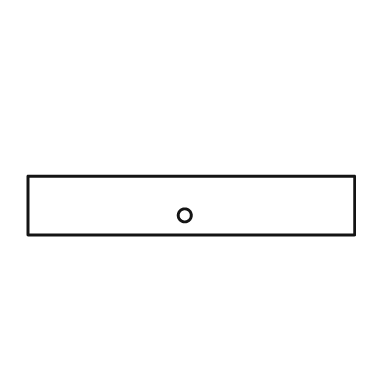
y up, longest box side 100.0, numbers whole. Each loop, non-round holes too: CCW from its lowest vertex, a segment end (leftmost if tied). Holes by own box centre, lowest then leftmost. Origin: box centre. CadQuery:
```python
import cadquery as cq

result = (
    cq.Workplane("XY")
    .moveTo(-50.0, -9.0)
    .lineTo(50.0, -9.0)
    .lineTo(50.0, 9.0)
    .lineTo(-50.0, 9.0)
    .close()
    .moveTo(-2.0, -3.0)
    .circle(2.0)
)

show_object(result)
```